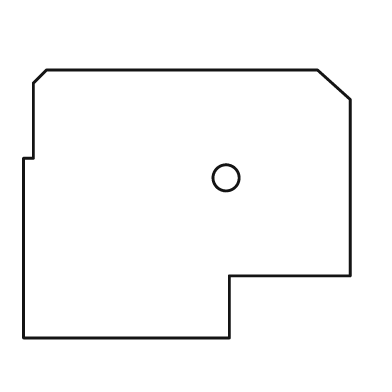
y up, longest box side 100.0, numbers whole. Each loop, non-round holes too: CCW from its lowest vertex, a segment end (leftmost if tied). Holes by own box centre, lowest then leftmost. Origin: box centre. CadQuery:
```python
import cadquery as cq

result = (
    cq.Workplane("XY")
    .moveTo(-50.0, -41.0)
    .lineTo(13.0, -41.0)
    .lineTo(13.0, -22.0)
    .lineTo(50.0, -22.0)
    .lineTo(50.0, 32.0)
    .lineTo(40.0, 41.0)
    .lineTo(-43.0, 41.0)
    .lineTo(-47.0, 37.0)
    .lineTo(-47.0, 14.0)
    .lineTo(-50.0, 14.0)
    .close()
    .moveTo(12.0, 8.0)
    .circle(4.0)
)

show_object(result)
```